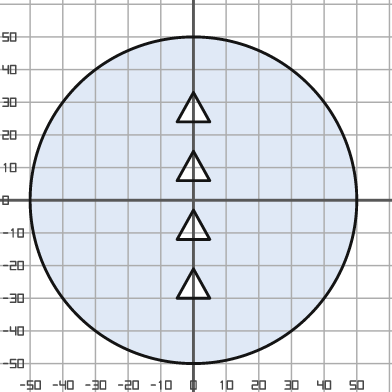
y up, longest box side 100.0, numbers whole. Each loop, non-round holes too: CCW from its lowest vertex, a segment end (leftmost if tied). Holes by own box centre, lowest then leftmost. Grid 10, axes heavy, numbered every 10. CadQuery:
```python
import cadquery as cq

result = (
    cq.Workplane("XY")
    .moveTo(0.0, 0.0)
    .circle(50.0)
    .moveTo(-5.0, -30.0)
    .lineTo(5.0, -30.0)
    .lineTo(0.0, -21.0)
    .close()
    .moveTo(-5.0, -12.0)
    .lineTo(5.0, -12.0)
    .lineTo(0.0, -3.0)
    .close()
    .moveTo(-5.0, 6.0)
    .lineTo(5.0, 6.0)
    .lineTo(0.0, 15.0)
    .close()
    .moveTo(-5.0, 24.0)
    .lineTo(5.0, 24.0)
    .lineTo(0.0, 33.0)
    .close()
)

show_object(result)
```